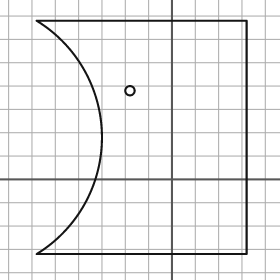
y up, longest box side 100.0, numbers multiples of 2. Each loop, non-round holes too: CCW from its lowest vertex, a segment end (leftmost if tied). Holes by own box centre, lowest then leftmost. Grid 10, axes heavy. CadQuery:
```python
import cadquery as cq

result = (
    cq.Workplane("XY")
    .moveTo(-58.0, -32.0)
    .lineTo(32.0, -32.0)
    .lineTo(32.0, 68.0)
    .lineTo(-58.0, 68.0)
    .threePointArc((-30.0, 18.0), (-58.0, -32.0))
    .close()
    .moveTo(-18.0, 38.0)
    .circle(2.0)
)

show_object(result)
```